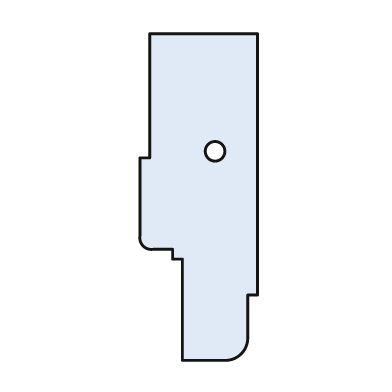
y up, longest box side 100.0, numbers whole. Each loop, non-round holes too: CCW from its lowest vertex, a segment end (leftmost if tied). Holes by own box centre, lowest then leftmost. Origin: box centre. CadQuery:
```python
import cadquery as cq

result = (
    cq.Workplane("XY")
    .moveTo(-5.0, -50.0)
    .lineTo(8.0, -50.0)
    .threePointArc((13.0, -48.0), (15.0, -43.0))
    .lineTo(15.0, -30.0)
    .lineTo(18.0, -30.0)
    .lineTo(18.0, 50.0)
    .lineTo(-15.0, 50.0)
    .lineTo(-15.0, 12.0)
    .lineTo(-18.0, 12.0)
    .lineTo(-18.0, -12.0)
    .threePointArc((-17.0, -15.0), (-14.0, -16.0))
    .lineTo(-8.0, -16.0)
    .lineTo(-8.0, -19.0)
    .lineTo(-5.0, -19.0)
    .close()
    .moveTo(5.0, 14.0)
    .circle(3.0)
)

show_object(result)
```